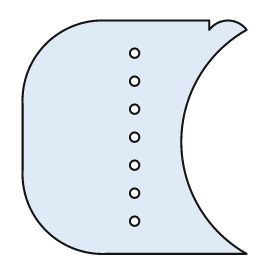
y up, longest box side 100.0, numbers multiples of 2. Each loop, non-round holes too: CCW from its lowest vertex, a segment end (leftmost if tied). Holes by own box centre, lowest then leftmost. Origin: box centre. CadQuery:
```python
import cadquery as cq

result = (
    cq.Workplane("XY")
    .moveTo(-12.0, -50.0)
    .lineTo(48.0, -50.0)
    .threePointArc((20.0, -2.0), (48.0, 46.0))
    .threePointArc((40.0, 50.0), (32.0, 46.0))
    .lineTo(32.0, 50.0)
    .lineTo(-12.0, 50.0)
    .threePointArc((-38.0, 40.0), (-48.0, 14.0))
    .lineTo(-48.0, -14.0)
    .threePointArc((-38.0, -40.0), (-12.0, -50.0))
    .close()
    .moveTo(0.0, -36.0)
    .circle(2.0)
    .moveTo(0.0, -24.0)
    .circle(2.0)
    .moveTo(0.0, -12.0)
    .circle(2.0)
    .moveTo(0.0, 0.0)
    .circle(2.0)
    .moveTo(0.0, 12.0)
    .circle(2.0)
    .moveTo(0.0, 24.0)
    .circle(2.0)
    .moveTo(0.0, 36.0)
    .circle(2.0)
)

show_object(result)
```